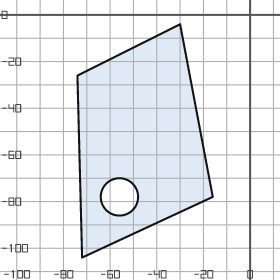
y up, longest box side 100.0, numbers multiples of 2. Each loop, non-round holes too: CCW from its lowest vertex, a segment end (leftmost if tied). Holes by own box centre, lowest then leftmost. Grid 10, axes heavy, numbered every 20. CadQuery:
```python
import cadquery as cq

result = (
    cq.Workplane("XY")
    .moveTo(-72.0, -104.0)
    .lineTo(-16.0, -78.0)
    .lineTo(-30.0, -4.0)
    .lineTo(-74.0, -26.0)
    .close()
    .moveTo(-56.0, -78.0)
    .circle(8.0)
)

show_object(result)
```